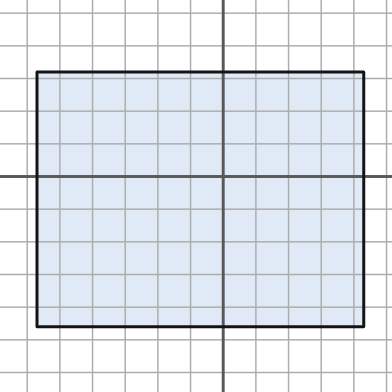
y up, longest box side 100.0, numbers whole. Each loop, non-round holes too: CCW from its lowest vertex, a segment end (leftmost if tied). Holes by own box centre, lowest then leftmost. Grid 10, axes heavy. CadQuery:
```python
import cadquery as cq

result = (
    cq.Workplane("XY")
    .moveTo(-57.0, -46.0)
    .lineTo(43.0, -46.0)
    .lineTo(43.0, 32.0)
    .lineTo(-57.0, 32.0)
    .close()
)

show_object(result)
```